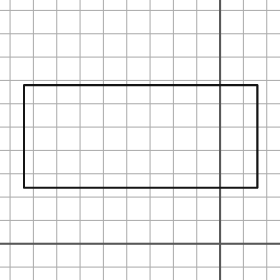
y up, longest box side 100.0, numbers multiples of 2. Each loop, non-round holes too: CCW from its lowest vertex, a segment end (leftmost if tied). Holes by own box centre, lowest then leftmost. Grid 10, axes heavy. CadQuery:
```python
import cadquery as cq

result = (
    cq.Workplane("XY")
    .moveTo(-84.0, 24.0)
    .lineTo(16.0, 24.0)
    .lineTo(16.0, 68.0)
    .lineTo(-84.0, 68.0)
    .close()
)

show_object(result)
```